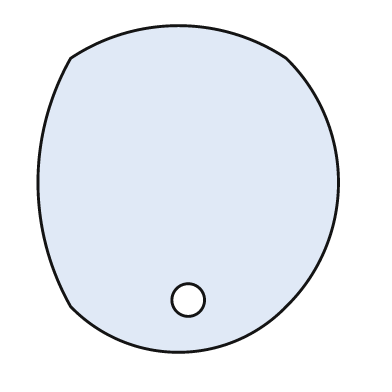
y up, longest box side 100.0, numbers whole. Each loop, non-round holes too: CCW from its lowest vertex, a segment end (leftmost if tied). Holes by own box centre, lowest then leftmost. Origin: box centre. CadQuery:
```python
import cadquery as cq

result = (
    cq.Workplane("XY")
    .moveTo(-36.0, -36.0)
    .threePointArc((-3.0, -50.0), (30.0, -36.0))
    .threePointArc((46.0, 2.0), (30.0, 40.0))
    .threePointArc((-3.0, 50.0), (-36.0, 40.0))
    .threePointArc((-46.0, 2.0), (-36.0, -36.0))
    .close()
    .moveTo(0.0, -34.0)
    .circle(5.0)
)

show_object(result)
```